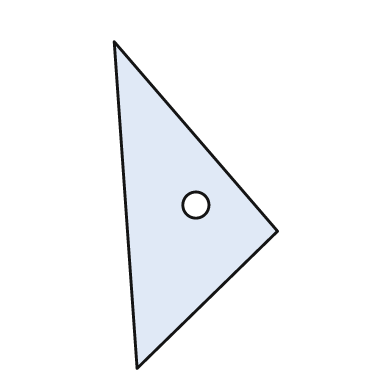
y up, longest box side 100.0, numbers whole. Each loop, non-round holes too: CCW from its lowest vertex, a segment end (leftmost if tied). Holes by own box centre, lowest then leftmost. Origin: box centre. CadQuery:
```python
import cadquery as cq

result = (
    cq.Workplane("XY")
    .moveTo(-18.0, -50.0)
    .lineTo(25.0, -8.0)
    .lineTo(-25.0, 50.0)
    .close()
    .moveTo(0.0, 0.0)
    .circle(4.0)
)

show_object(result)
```